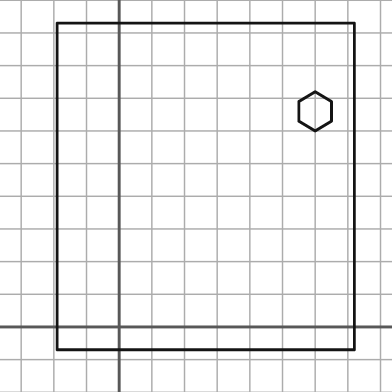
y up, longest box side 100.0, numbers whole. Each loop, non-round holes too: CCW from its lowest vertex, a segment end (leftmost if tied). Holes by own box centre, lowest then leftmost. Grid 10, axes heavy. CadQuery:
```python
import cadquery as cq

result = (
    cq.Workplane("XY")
    .moveTo(-19.0, -7.0)
    .lineTo(72.0, -7.0)
    .lineTo(72.0, 93.0)
    .lineTo(-19.0, 93.0)
    .close()
    .moveTo(60.0, 60.0)
    .lineTo(65.0, 63.0)
    .lineTo(65.0, 69.0)
    .lineTo(60.0, 72.0)
    .lineTo(55.0, 69.0)
    .lineTo(55.0, 63.0)
    .close()
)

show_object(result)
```